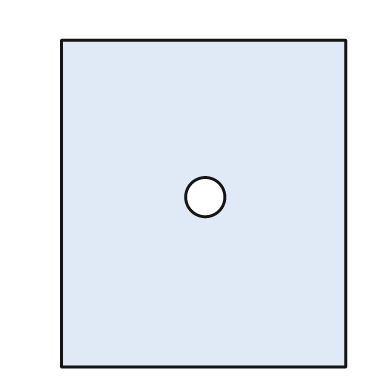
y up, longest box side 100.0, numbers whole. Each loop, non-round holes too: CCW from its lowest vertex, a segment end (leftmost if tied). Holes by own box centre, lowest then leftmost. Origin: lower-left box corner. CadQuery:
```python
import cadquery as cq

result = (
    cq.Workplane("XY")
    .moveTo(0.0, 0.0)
    .lineTo(87.0, 0.0)
    .lineTo(87.0, 100.0)
    .lineTo(0.0, 100.0)
    .close()
    .moveTo(44.0, 52.0)
    .circle(6.0)
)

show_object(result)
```